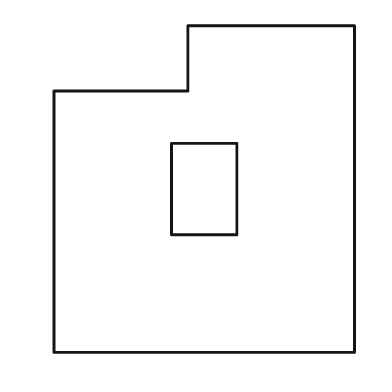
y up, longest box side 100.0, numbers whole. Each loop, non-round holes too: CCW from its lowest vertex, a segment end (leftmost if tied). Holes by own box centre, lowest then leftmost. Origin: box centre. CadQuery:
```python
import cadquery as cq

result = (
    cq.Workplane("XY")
    .moveTo(-46.0, -50.0)
    .lineTo(46.0, -50.0)
    .lineTo(46.0, 50.0)
    .lineTo(-5.0, 50.0)
    .lineTo(-5.0, 30.0)
    .lineTo(-46.0, 30.0)
    .close()
    .moveTo(-10.0, -14.0)
    .lineTo(10.0, -14.0)
    .lineTo(10.0, 14.0)
    .lineTo(-10.0, 14.0)
    .close()
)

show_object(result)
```